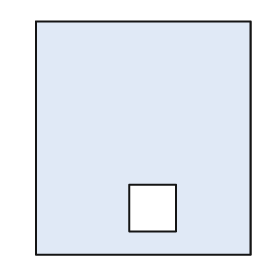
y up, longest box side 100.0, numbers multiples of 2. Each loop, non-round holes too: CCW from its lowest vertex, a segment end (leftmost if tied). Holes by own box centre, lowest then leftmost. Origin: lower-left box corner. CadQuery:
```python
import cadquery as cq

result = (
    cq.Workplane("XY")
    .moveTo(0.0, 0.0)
    .lineTo(92.0, 0.0)
    .lineTo(92.0, 100.0)
    .lineTo(0.0, 100.0)
    .close()
    .moveTo(40.0, 10.0)
    .lineTo(60.0, 10.0)
    .lineTo(60.0, 30.0)
    .lineTo(40.0, 30.0)
    .close()
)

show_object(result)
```